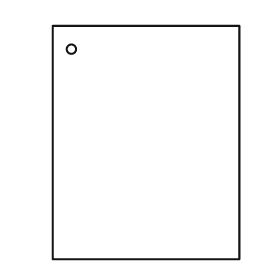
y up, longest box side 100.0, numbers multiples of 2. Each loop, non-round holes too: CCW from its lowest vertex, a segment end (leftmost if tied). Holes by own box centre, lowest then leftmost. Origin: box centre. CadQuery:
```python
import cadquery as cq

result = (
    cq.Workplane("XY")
    .moveTo(-40.0, -50.0)
    .lineTo(40.0, -50.0)
    .lineTo(40.0, 50.0)
    .lineTo(-40.0, 50.0)
    .close()
    .moveTo(-32.0, 40.0)
    .circle(2.0)
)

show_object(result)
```